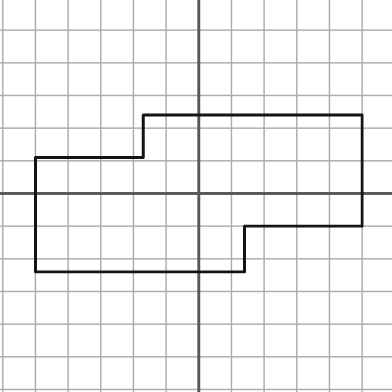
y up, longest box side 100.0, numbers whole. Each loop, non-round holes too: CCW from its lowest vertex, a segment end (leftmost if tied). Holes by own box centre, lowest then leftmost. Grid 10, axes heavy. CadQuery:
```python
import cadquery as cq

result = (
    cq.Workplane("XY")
    .moveTo(-50.0, -24.0)
    .lineTo(14.0, -24.0)
    .lineTo(14.0, -10.0)
    .lineTo(50.0, -10.0)
    .lineTo(50.0, 24.0)
    .lineTo(-17.0, 24.0)
    .lineTo(-17.0, 11.0)
    .lineTo(-50.0, 11.0)
    .close()
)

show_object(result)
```